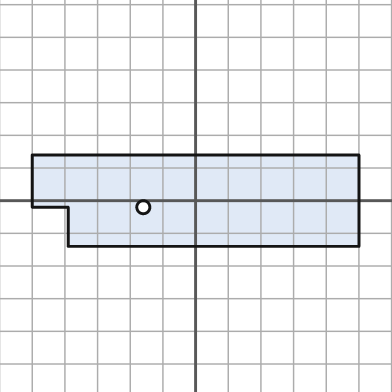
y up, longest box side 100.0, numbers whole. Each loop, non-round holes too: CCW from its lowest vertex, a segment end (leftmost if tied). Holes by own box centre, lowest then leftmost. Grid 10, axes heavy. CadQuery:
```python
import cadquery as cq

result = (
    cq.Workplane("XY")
    .moveTo(-39.0, -14.0)
    .lineTo(50.0, -14.0)
    .lineTo(50.0, 14.0)
    .lineTo(-50.0, 14.0)
    .lineTo(-50.0, -2.0)
    .lineTo(-39.0, -2.0)
    .close()
    .moveTo(-16.0, -2.0)
    .circle(2.0)
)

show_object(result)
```